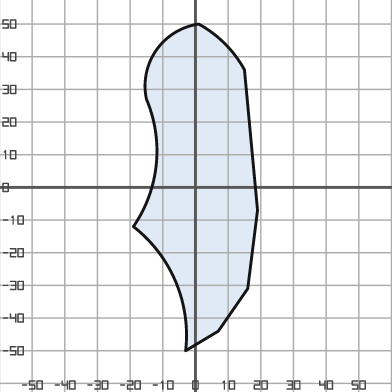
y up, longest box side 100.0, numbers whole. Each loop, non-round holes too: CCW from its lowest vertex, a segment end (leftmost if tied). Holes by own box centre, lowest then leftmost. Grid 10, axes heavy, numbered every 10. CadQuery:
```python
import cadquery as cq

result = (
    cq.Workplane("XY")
    .moveTo(-3.0, -50.0)
    .lineTo(7.0, -44.0)
    .lineTo(16.0, -31.0)
    .lineTo(19.0, -7.0)
    .lineTo(15.0, 36.0)
    .threePointArc((9.0, 44.0), (1.0, 50.0))
    .threePointArc((-12.0, 42.0), (-15.0, 27.0))
    .threePointArc((-12.0, 7.0), (-19.0, -12.0))
    .threePointArc((-6.0, -29.0), (-3.0, -50.0))
    .close()
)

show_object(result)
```